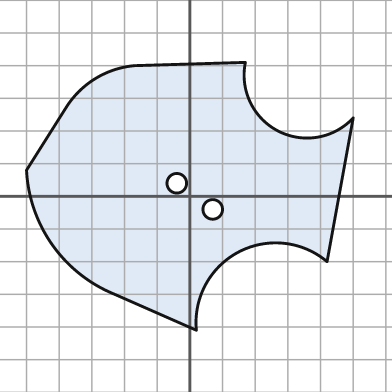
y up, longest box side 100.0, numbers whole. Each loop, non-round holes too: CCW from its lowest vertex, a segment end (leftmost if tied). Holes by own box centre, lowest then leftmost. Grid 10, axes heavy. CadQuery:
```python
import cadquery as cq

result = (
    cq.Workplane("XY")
    .moveTo(2.0, -41.0)
    .threePointArc((15.0, -17.0), (42.0, -20.0))
    .lineTo(50.0, 24.0)
    .threePointArc((27.0, 20.0), (17.0, 41.0))
    .lineTo(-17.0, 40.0)
    .threePointArc((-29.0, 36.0), (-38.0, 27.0))
    .lineTo(-50.0, 8.0)
    .threePointArc((-42.0, -15.0), (-23.0, -30.0))
    .close()
    .moveTo(7.0, -4.0)
    .circle(3.0)
    .moveTo(-4.0, 4.0)
    .circle(3.0)
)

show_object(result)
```